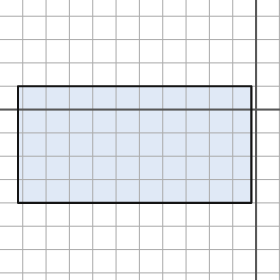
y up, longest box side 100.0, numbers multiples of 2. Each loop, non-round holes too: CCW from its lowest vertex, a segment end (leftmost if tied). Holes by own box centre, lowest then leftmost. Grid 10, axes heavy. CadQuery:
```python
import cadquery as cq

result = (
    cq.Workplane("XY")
    .moveTo(-102.0, -40.0)
    .lineTo(-2.0, -40.0)
    .lineTo(-2.0, 10.0)
    .lineTo(-102.0, 10.0)
    .close()
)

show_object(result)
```